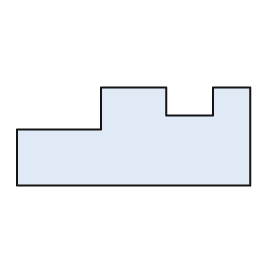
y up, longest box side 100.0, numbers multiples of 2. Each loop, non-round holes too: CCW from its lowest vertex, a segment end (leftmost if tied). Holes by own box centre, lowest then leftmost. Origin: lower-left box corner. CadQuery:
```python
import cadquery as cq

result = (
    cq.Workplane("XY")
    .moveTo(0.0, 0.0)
    .lineTo(100.0, 0.0)
    .lineTo(100.0, 42.0)
    .lineTo(84.0, 42.0)
    .lineTo(84.0, 30.0)
    .lineTo(64.0, 30.0)
    .lineTo(64.0, 42.0)
    .lineTo(36.0, 42.0)
    .lineTo(36.0, 24.0)
    .lineTo(0.0, 24.0)
    .close()
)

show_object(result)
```